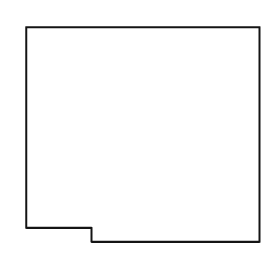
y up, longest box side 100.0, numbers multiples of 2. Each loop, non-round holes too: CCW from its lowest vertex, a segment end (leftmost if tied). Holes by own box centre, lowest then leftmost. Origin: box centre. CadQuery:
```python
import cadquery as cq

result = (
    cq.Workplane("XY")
    .moveTo(-22.0, -46.0)
    .lineTo(50.0, -46.0)
    .lineTo(50.0, 46.0)
    .lineTo(-50.0, 46.0)
    .lineTo(-50.0, -40.0)
    .lineTo(-22.0, -40.0)
    .close()
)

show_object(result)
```